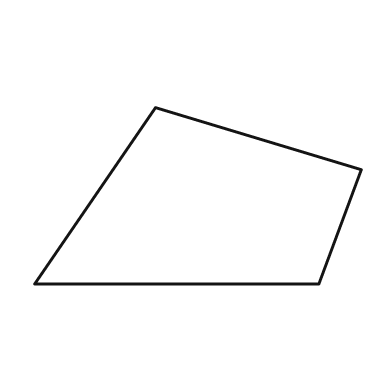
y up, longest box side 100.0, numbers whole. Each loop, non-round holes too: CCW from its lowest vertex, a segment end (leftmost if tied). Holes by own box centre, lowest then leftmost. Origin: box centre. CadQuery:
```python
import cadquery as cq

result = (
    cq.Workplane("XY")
    .moveTo(-50.0, -27.0)
    .lineTo(37.0, -27.0)
    .lineTo(50.0, 8.0)
    .lineTo(-13.0, 27.0)
    .close()
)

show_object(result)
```